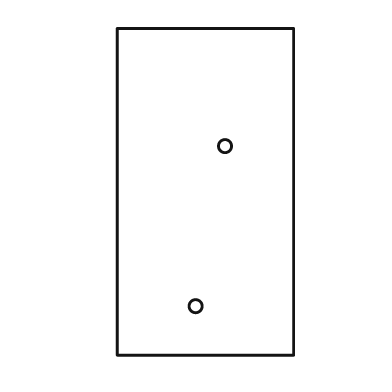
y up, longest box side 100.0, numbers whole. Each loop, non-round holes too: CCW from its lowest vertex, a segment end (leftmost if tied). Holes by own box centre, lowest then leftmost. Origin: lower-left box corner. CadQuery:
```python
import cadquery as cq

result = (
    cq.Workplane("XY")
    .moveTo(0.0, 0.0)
    .lineTo(54.0, 0.0)
    .lineTo(54.0, 100.0)
    .lineTo(0.0, 100.0)
    .close()
    .moveTo(24.0, 15.0)
    .circle(2.0)
    .moveTo(33.0, 64.0)
    .circle(2.0)
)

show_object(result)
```